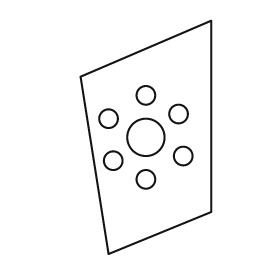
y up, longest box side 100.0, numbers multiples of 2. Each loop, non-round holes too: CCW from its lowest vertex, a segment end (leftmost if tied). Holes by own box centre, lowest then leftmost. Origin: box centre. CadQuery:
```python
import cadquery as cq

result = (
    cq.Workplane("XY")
    .moveTo(-16.0, -50.0)
    .lineTo(28.0, -32.0)
    .lineTo(28.0, 50.0)
    .lineTo(-28.0, 26.0)
    .close()
    .moveTo(0.0, -18.0)
    .circle(4.0)
    .moveTo(-14.0, -10.0)
    .circle(4.0)
    .moveTo(16.0, -8.0)
    .circle(4.0)
    .moveTo(0.0, 0.0)
    .circle(8.0)
    .moveTo(-16.0, 8.0)
    .circle(4.0)
    .moveTo(14.0, 10.0)
    .circle(4.0)
    .moveTo(0.0, 18.0)
    .circle(4.0)
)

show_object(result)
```